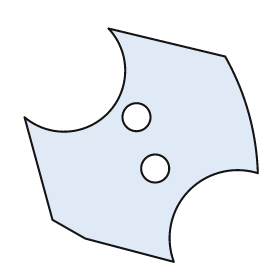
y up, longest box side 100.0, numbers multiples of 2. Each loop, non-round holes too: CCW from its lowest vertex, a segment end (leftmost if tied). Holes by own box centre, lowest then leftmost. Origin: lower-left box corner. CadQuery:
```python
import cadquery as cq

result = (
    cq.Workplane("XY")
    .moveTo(64.0, 0.0)
    .threePointArc((70.0, 30.0), (100.0, 38.0))
    .threePointArc((96.0, 64.0), (86.0, 88.0))
    .lineTo(36.0, 100.0)
    .threePointArc((36.0, 64.0), (0.0, 62.0))
    .lineTo(12.0, 18.0)
    .lineTo(26.0, 10.0)
    .close()
    .moveTo(56.0, 40.0)
    .circle(6.0)
    .moveTo(48.0, 62.0)
    .circle(6.0)
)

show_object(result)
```